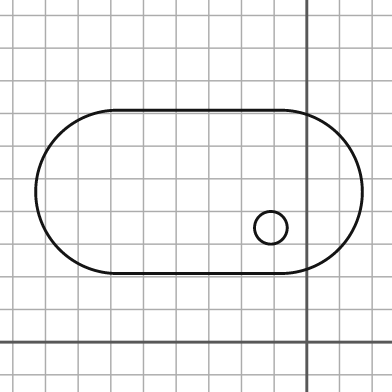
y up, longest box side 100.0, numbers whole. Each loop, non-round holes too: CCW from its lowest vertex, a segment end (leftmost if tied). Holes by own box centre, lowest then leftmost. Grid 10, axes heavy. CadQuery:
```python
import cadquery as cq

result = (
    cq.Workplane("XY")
    .moveTo(-58.0, 21.0)
    .lineTo(-8.0, 21.0)
    .threePointArc((17.0, 46.0), (-8.0, 71.0))
    .lineTo(-58.0, 71.0)
    .threePointArc((-83.0, 46.0), (-58.0, 21.0))
    .close()
    .moveTo(-11.0, 35.0)
    .circle(5.0)
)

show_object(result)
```